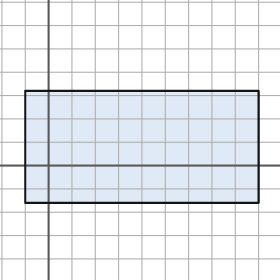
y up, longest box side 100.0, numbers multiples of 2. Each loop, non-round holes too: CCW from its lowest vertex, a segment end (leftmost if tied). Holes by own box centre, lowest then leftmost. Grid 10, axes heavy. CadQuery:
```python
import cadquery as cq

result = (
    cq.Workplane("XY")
    .moveTo(-10.0, -16.0)
    .lineTo(90.0, -16.0)
    .lineTo(90.0, 32.0)
    .lineTo(-10.0, 32.0)
    .close()
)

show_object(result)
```